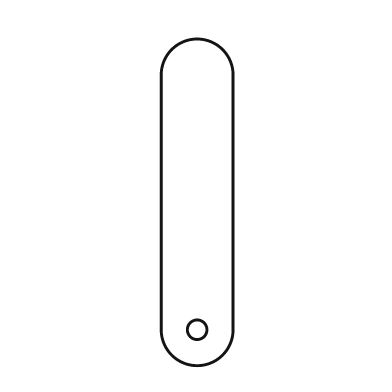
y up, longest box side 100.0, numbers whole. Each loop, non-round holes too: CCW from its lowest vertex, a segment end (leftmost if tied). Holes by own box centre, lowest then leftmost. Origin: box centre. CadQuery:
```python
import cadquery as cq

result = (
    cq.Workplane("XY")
    .moveTo(-11.0, -39.0)
    .threePointArc((0.0, -50.0), (11.0, -39.0))
    .lineTo(11.0, 39.0)
    .threePointArc((0.0, 50.0), (-11.0, 39.0))
    .close()
    .moveTo(0.0, -39.0)
    .circle(3.0)
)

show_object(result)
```